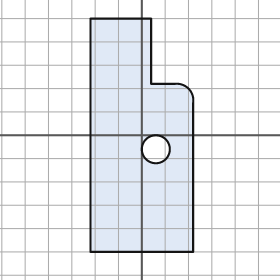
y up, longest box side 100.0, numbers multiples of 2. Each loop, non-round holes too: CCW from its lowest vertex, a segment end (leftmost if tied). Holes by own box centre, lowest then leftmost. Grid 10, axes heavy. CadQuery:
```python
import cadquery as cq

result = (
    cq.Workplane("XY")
    .moveTo(-22.0, -50.0)
    .lineTo(22.0, -50.0)
    .lineTo(22.0, 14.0)
    .threePointArc((20.0, 20.0), (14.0, 22.0))
    .lineTo(4.0, 22.0)
    .lineTo(4.0, 50.0)
    .lineTo(-22.0, 50.0)
    .close()
    .moveTo(6.0, -6.0)
    .circle(6.0)
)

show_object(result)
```